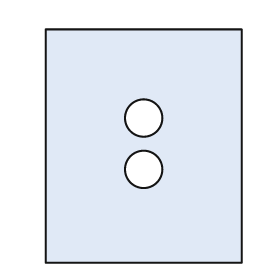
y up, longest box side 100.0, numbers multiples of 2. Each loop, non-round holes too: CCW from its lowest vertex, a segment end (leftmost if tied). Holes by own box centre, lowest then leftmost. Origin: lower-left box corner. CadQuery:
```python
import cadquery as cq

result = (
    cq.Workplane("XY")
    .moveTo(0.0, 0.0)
    .lineTo(84.0, 0.0)
    .lineTo(84.0, 100.0)
    .lineTo(0.0, 100.0)
    .close()
    .moveTo(42.0, 40.0)
    .circle(8.0)
    .moveTo(42.0, 62.0)
    .circle(8.0)
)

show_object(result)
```